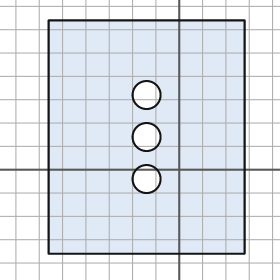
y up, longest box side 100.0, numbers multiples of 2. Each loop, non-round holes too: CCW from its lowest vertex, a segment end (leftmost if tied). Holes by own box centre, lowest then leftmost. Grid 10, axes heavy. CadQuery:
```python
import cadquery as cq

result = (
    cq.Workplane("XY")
    .moveTo(-56.0, -36.0)
    .lineTo(28.0, -36.0)
    .lineTo(28.0, 64.0)
    .lineTo(-56.0, 64.0)
    .close()
    .moveTo(-14.0, -4.0)
    .circle(6.0)
    .moveTo(-14.0, 14.0)
    .circle(6.0)
    .moveTo(-14.0, 32.0)
    .circle(6.0)
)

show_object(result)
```